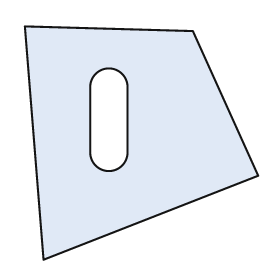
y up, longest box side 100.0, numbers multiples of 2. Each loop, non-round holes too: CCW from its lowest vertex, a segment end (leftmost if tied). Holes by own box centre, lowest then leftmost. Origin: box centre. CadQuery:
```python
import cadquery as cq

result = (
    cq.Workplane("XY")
    .moveTo(-42.0, -50.0)
    .lineTo(50.0, -14.0)
    .lineTo(22.0, 48.0)
    .lineTo(-50.0, 50.0)
    .close()
    .moveTo(-22.0, -4.0)
    .threePointArc((-14.0, -12.0), (-6.0, -4.0))
    .lineTo(-6.0, 24.0)
    .threePointArc((-14.0, 32.0), (-22.0, 24.0))
    .close()
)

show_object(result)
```